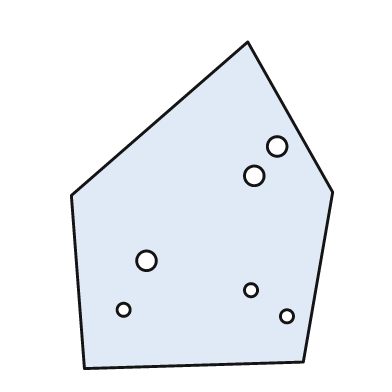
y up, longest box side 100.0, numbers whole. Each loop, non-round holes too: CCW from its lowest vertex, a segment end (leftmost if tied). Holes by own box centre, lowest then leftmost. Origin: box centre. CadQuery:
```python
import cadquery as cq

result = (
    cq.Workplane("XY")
    .moveTo(-36.0, -50.0)
    .lineTo(31.0, -48.0)
    .lineTo(40.0, 4.0)
    .lineTo(14.0, 50.0)
    .lineTo(-40.0, 3.0)
    .close()
    .moveTo(26.0, -34.0)
    .circle(2.0)
    .moveTo(-24.0, -32.0)
    .circle(2.0)
    .moveTo(15.0, -26.0)
    .circle(2.0)
    .moveTo(-17.0, -17.0)
    .circle(3.0)
    .moveTo(16.0, 9.0)
    .circle(3.0)
    .moveTo(23.0, 18.0)
    .circle(3.0)
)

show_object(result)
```